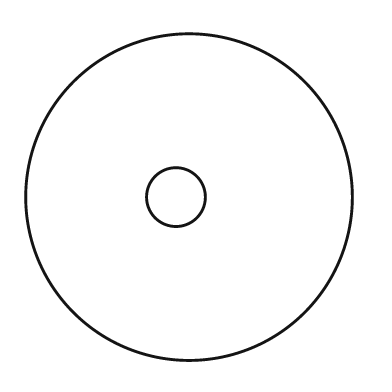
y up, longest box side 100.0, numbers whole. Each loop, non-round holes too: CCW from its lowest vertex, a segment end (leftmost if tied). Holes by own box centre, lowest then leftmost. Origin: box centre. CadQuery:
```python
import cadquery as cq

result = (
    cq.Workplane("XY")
    .moveTo(0.0, 0.0)
    .circle(50.0)
    .moveTo(-4.0, 0.0)
    .circle(9.0)
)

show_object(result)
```